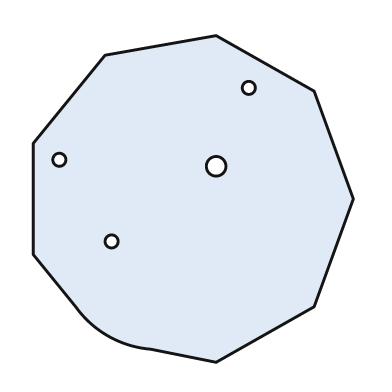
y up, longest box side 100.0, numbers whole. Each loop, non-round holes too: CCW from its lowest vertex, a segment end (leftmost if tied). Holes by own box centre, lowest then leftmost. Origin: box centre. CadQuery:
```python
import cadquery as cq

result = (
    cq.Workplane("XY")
    .moveTo(7.0, -50.0)
    .lineTo(37.0, -33.0)
    .lineTo(49.0, 0.0)
    .lineTo(37.0, 33.0)
    .lineTo(7.0, 50.0)
    .lineTo(-27.0, 44.0)
    .lineTo(-49.0, 17.0)
    .lineTo(-49.0, -17.0)
    .lineTo(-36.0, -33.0)
    .threePointArc((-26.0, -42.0), (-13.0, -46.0))
    .close()
    .moveTo(-25.0, -13.0)
    .circle(2.0)
    .moveTo(7.0, 10.0)
    .circle(3.0)
    .moveTo(-41.0, 12.0)
    .circle(2.0)
    .moveTo(17.0, 34.0)
    .circle(2.0)
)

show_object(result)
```